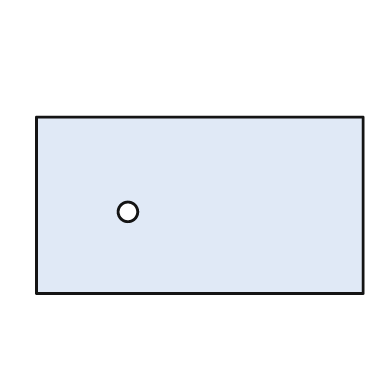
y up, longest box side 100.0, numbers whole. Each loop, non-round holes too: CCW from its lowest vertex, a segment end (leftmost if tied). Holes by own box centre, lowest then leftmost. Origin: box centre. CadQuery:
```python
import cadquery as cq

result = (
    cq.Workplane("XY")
    .moveTo(-50.0, -27.0)
    .lineTo(50.0, -27.0)
    .lineTo(50.0, 27.0)
    .lineTo(-50.0, 27.0)
    .close()
    .moveTo(-22.0, -2.0)
    .circle(3.0)
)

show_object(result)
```